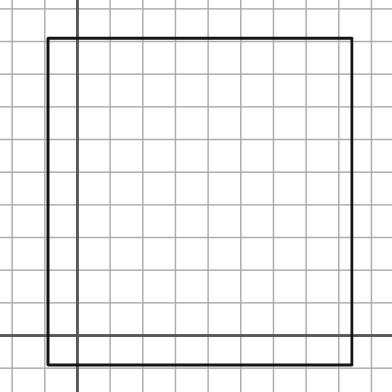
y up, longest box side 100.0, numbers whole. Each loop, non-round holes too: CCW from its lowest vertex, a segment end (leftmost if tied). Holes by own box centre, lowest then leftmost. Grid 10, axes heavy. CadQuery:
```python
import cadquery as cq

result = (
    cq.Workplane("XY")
    .moveTo(-9.0, -9.0)
    .lineTo(84.0, -9.0)
    .lineTo(84.0, 91.0)
    .lineTo(-9.0, 91.0)
    .close()
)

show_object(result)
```